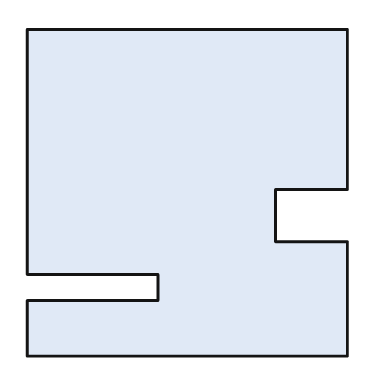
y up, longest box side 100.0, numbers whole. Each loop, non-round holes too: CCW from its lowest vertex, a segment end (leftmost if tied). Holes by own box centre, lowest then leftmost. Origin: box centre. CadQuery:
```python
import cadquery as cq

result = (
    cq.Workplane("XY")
    .moveTo(-49.0, -50.0)
    .lineTo(49.0, -50.0)
    .lineTo(49.0, -15.0)
    .lineTo(27.0, -15.0)
    .lineTo(27.0, 1.0)
    .lineTo(49.0, 1.0)
    .lineTo(49.0, 50.0)
    .lineTo(-49.0, 50.0)
    .lineTo(-49.0, -25.0)
    .lineTo(-9.0, -25.0)
    .lineTo(-9.0, -33.0)
    .lineTo(-49.0, -33.0)
    .close()
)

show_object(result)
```